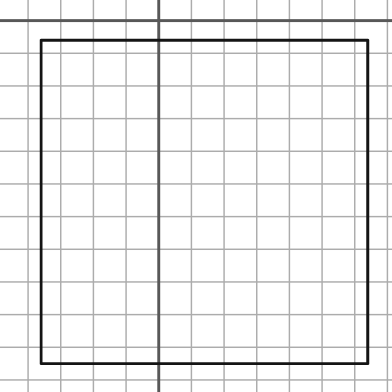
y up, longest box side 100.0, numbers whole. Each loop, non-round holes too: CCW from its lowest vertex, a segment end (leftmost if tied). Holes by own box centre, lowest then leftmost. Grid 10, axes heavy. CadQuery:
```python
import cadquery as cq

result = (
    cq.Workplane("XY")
    .moveTo(-36.0, -105.0)
    .lineTo(64.0, -105.0)
    .lineTo(64.0, -6.0)
    .lineTo(-36.0, -6.0)
    .close()
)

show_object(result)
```